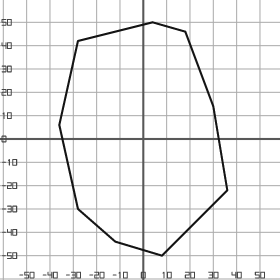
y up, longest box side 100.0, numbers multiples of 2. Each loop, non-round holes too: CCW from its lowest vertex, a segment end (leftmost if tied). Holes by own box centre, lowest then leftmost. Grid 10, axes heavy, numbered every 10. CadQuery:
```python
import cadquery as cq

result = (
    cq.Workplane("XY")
    .moveTo(8.0, -50.0)
    .lineTo(36.0, -22.0)
    .lineTo(30.0, 14.0)
    .lineTo(18.0, 46.0)
    .lineTo(4.0, 50.0)
    .lineTo(-28.0, 42.0)
    .lineTo(-36.0, 6.0)
    .lineTo(-28.0, -30.0)
    .lineTo(-12.0, -44.0)
    .close()
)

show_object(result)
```